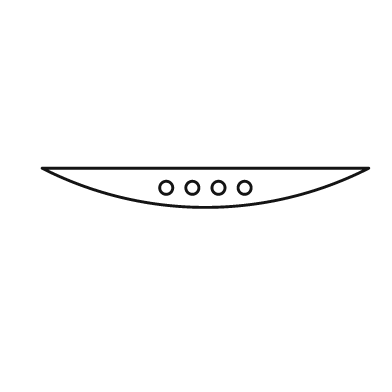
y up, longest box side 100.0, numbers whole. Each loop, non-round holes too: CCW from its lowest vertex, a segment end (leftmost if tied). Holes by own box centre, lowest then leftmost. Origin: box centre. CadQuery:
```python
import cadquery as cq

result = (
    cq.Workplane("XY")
    .moveTo(-50.0, 6.0)
    .threePointArc((0.0, -6.0), (50.0, 6.0))
    .close()
    .moveTo(-12.0, 0.0)
    .circle(2.0)
    .moveTo(-4.0, 0.0)
    .circle(2.0)
    .moveTo(4.0, 0.0)
    .circle(2.0)
    .moveTo(12.0, 0.0)
    .circle(2.0)
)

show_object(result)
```